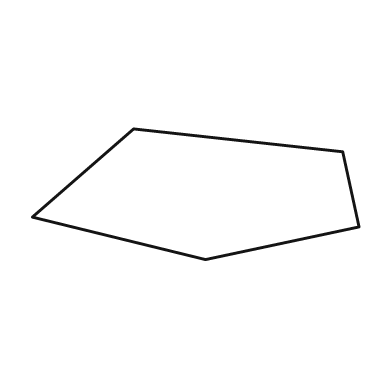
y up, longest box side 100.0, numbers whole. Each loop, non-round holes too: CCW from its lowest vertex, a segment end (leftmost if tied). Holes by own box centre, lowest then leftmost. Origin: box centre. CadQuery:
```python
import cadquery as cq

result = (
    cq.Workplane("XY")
    .moveTo(3.0, -20.0)
    .lineTo(50.0, -10.0)
    .lineTo(45.0, 13.0)
    .lineTo(-19.0, 20.0)
    .lineTo(-50.0, -7.0)
    .close()
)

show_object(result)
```